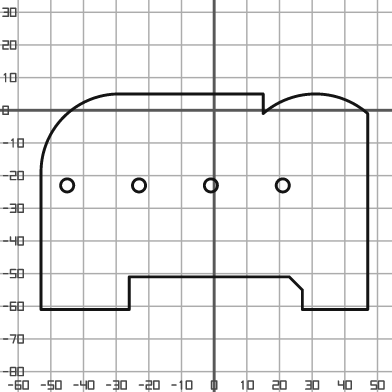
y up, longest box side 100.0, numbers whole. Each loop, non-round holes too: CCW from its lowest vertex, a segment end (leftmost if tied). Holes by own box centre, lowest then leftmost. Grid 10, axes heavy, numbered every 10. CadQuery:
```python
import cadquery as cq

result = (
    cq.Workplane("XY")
    .moveTo(-53.0, -61.0)
    .lineTo(-26.0, -61.0)
    .lineTo(-26.0, -51.0)
    .lineTo(23.0, -51.0)
    .lineTo(27.0, -55.0)
    .lineTo(27.0, -61.0)
    .lineTo(47.0, -61.0)
    .lineTo(47.0, -1.0)
    .threePointArc((31.0, 5.0), (15.0, -1.0))
    .lineTo(15.0, 5.0)
    .lineTo(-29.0, 5.0)
    .threePointArc((-46.0, -2.0), (-53.0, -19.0))
    .close()
    .moveTo(-45.0, -23.0)
    .circle(2.0)
    .moveTo(-23.0, -23.0)
    .circle(2.0)
    .moveTo(-1.0, -23.0)
    .circle(2.0)
    .moveTo(21.0, -23.0)
    .circle(2.0)
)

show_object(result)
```